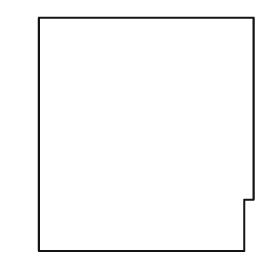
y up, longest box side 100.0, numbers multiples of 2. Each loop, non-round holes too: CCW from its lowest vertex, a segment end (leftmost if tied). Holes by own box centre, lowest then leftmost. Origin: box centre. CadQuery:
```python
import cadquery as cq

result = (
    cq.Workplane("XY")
    .moveTo(-46.0, -50.0)
    .lineTo(42.0, -50.0)
    .lineTo(42.0, -28.0)
    .lineTo(46.0, -28.0)
    .lineTo(46.0, 50.0)
    .lineTo(-46.0, 50.0)
    .close()
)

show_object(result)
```